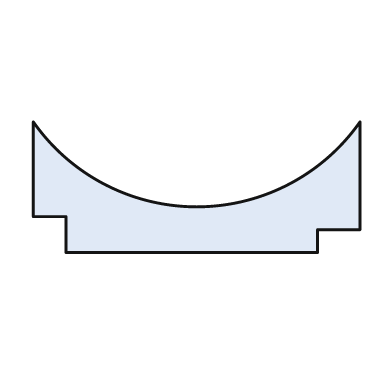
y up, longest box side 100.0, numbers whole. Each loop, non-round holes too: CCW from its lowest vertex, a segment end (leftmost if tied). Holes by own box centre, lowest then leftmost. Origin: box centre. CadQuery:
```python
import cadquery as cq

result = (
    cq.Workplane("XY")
    .moveTo(-40.0, -20.0)
    .lineTo(37.0, -20.0)
    .lineTo(37.0, -13.0)
    .lineTo(50.0, -13.0)
    .lineTo(50.0, 20.0)
    .threePointArc((0.0, -6.0), (-50.0, 20.0))
    .lineTo(-50.0, -9.0)
    .lineTo(-40.0, -9.0)
    .close()
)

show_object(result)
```